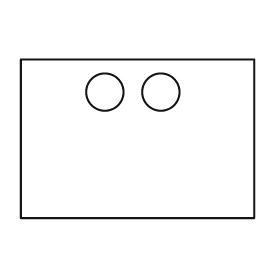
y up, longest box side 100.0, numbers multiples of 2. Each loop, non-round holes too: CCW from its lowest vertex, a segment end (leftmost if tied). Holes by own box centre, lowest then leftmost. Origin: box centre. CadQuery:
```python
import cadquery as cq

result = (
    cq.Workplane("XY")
    .moveTo(-50.0, -34.0)
    .lineTo(50.0, -34.0)
    .lineTo(50.0, 34.0)
    .lineTo(-50.0, 34.0)
    .close()
    .moveTo(-14.0, 20.0)
    .circle(8.0)
    .moveTo(10.0, 20.0)
    .circle(8.0)
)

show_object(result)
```